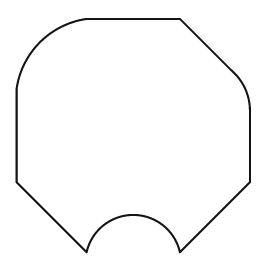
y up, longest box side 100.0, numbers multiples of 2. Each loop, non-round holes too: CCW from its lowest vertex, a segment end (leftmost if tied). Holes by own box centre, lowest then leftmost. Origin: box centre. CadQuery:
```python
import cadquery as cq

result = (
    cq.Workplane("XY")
    .moveTo(-20.0, -50.0)
    .threePointArc((0.0, -34.0), (20.0, -50.0))
    .lineTo(50.0, -20.0)
    .lineTo(50.0, 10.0)
    .threePointArc((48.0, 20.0), (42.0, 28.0))
    .lineTo(20.0, 50.0)
    .lineTo(-20.0, 50.0)
    .threePointArc((-40.0, 40.0), (-50.0, 20.0))
    .lineTo(-50.0, -20.0)
    .close()
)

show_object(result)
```